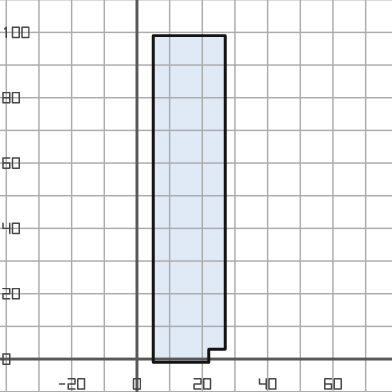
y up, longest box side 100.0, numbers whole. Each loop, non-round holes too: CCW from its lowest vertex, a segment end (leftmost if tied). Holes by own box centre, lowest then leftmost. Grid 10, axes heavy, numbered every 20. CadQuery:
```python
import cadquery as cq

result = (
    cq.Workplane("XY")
    .moveTo(5.0, -1.0)
    .lineTo(22.0, -1.0)
    .lineTo(22.0, 3.0)
    .lineTo(27.0, 3.0)
    .lineTo(27.0, 99.0)
    .lineTo(5.0, 99.0)
    .close()
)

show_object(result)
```